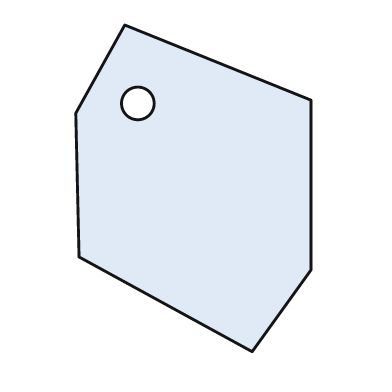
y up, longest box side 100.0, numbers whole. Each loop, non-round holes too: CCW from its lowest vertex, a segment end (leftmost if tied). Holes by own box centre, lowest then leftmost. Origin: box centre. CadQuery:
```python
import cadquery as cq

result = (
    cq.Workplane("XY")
    .moveTo(18.0, -50.0)
    .lineTo(36.0, -25.0)
    .lineTo(36.0, 27.0)
    .lineTo(-21.0, 50.0)
    .lineTo(-36.0, 23.0)
    .lineTo(-35.0, -21.0)
    .close()
    .moveTo(-17.0, 26.0)
    .circle(5.0)
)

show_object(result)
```